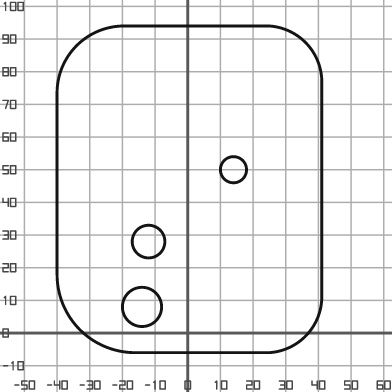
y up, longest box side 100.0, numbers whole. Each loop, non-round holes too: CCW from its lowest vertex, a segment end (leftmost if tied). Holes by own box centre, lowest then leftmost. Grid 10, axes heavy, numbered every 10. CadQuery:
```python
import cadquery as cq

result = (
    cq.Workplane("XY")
    .moveTo(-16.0, -6.0)
    .lineTo(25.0, -6.0)
    .threePointArc((36.0, -1.0), (41.0, 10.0))
    .lineTo(41.0, 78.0)
    .threePointArc((36.0, 89.0), (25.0, 94.0))
    .lineTo(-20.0, 94.0)
    .threePointArc((-34.0, 88.0), (-40.0, 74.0))
    .lineTo(-40.0, 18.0)
    .threePointArc((-33.0, 1.0), (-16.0, -6.0))
    .close()
    .moveTo(-14.0, 8.0)
    .circle(6.0)
    .moveTo(-12.0, 28.0)
    .circle(5.0)
    .moveTo(14.0, 50.0)
    .circle(4.0)
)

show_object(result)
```